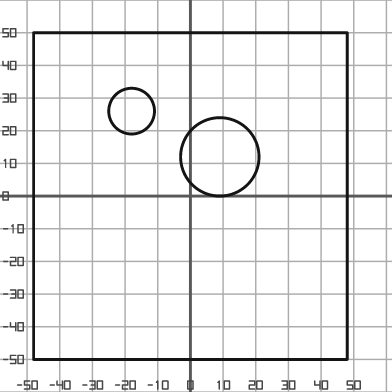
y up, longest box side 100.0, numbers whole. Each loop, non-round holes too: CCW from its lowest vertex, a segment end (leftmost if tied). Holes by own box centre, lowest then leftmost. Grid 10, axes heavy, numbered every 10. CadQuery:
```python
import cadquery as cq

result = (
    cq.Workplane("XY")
    .moveTo(-48.0, -50.0)
    .lineTo(48.0, -50.0)
    .lineTo(48.0, 50.0)
    .lineTo(-48.0, 50.0)
    .close()
    .moveTo(9.0, 12.0)
    .circle(12.0)
    .moveTo(-18.0, 26.0)
    .circle(7.0)
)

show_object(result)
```